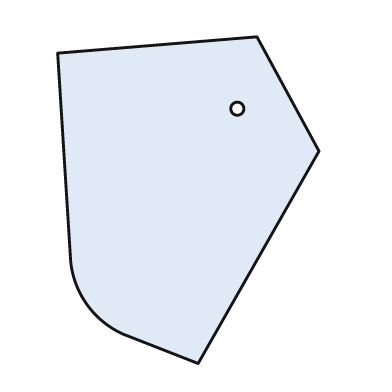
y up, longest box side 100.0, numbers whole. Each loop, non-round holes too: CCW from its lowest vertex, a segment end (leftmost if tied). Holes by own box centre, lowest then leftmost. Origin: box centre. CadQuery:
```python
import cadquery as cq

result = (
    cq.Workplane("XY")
    .moveTo(3.0, -50.0)
    .lineTo(40.0, 15.0)
    .lineTo(21.0, 50.0)
    .lineTo(-40.0, 45.0)
    .lineTo(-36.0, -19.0)
    .threePointArc((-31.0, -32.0), (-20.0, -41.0))
    .close()
    .moveTo(15.0, 28.0)
    .circle(2.0)
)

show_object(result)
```